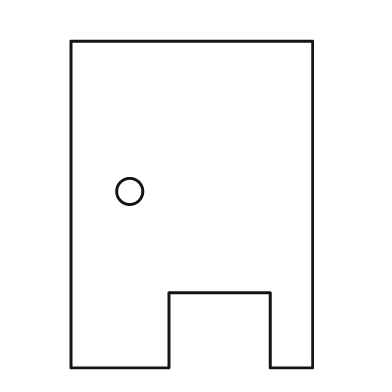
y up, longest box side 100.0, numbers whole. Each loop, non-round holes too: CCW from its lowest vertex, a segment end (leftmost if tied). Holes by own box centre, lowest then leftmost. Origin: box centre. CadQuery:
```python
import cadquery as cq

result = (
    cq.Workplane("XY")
    .moveTo(-37.0, -50.0)
    .lineTo(-7.0, -50.0)
    .lineTo(-7.0, -27.0)
    .lineTo(24.0, -27.0)
    .lineTo(24.0, -50.0)
    .lineTo(37.0, -50.0)
    .lineTo(37.0, 50.0)
    .lineTo(-37.0, 50.0)
    .close()
    .moveTo(-19.0, 4.0)
    .circle(4.0)
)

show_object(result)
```